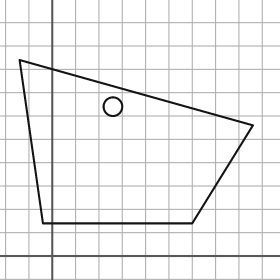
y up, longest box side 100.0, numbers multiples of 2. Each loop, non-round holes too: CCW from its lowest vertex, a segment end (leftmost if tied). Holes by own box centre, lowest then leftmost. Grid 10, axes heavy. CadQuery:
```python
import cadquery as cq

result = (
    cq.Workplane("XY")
    .moveTo(-4.0, 14.0)
    .lineTo(60.0, 14.0)
    .lineTo(86.0, 56.0)
    .lineTo(-14.0, 84.0)
    .close()
    .moveTo(26.0, 64.0)
    .circle(4.0)
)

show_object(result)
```